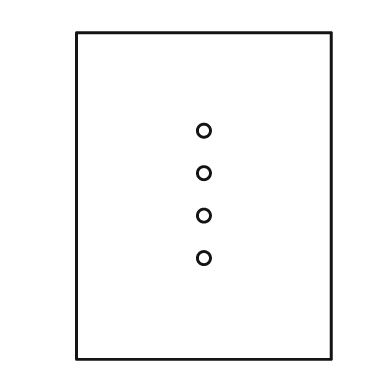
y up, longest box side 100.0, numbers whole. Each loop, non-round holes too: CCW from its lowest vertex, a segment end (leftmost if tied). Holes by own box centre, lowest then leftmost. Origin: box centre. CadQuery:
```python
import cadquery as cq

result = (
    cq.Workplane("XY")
    .moveTo(-39.0, -50.0)
    .lineTo(39.0, -50.0)
    .lineTo(39.0, 50.0)
    .lineTo(-39.0, 50.0)
    .close()
    .moveTo(0.0, -19.0)
    .circle(2.0)
    .moveTo(0.0, -6.0)
    .circle(2.0)
    .moveTo(0.0, 7.0)
    .circle(2.0)
    .moveTo(0.0, 20.0)
    .circle(2.0)
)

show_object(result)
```